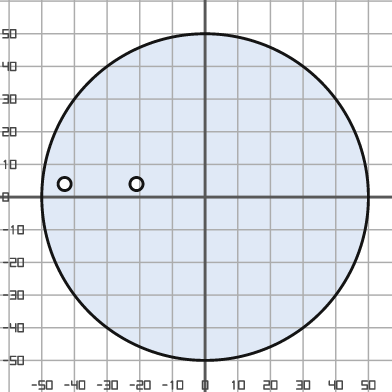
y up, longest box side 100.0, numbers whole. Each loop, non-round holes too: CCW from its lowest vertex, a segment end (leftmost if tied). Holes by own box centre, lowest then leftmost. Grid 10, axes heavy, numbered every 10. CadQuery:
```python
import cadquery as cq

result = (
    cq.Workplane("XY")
    .moveTo(0.0, 0.0)
    .circle(50.0)
    .moveTo(-43.0, 4.0)
    .circle(2.0)
    .moveTo(-21.0, 4.0)
    .circle(2.0)
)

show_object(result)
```